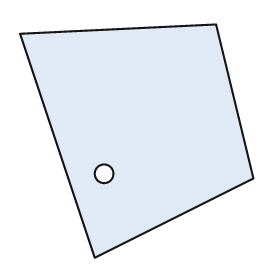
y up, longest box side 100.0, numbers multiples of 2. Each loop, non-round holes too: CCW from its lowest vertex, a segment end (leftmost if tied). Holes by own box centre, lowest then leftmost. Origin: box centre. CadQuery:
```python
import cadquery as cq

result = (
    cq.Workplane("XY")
    .moveTo(-18.0, -50.0)
    .lineTo(50.0, -16.0)
    .lineTo(34.0, 50.0)
    .lineTo(-50.0, 46.0)
    .close()
    .moveTo(-14.0, -14.0)
    .circle(4.0)
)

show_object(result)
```